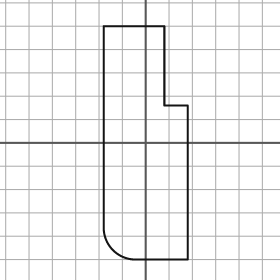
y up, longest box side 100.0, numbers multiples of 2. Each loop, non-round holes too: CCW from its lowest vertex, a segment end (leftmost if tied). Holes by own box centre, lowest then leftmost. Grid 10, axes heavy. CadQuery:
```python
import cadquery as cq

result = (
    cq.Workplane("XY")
    .moveTo(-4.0, -50.0)
    .lineTo(18.0, -50.0)
    .lineTo(18.0, 16.0)
    .lineTo(8.0, 16.0)
    .lineTo(8.0, 50.0)
    .lineTo(-18.0, 50.0)
    .lineTo(-18.0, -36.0)
    .threePointArc((-14.0, -46.0), (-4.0, -50.0))
    .close()
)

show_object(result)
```